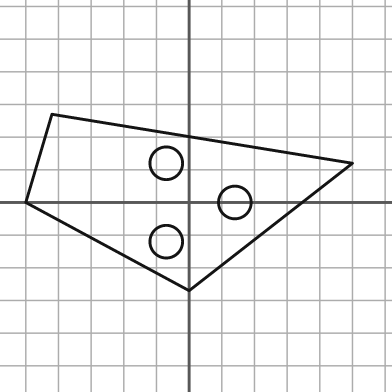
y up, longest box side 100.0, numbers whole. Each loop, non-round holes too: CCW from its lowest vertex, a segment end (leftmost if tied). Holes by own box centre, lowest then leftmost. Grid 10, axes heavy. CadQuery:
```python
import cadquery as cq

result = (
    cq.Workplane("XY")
    .moveTo(0.0, -27.0)
    .lineTo(50.0, 12.0)
    .lineTo(-42.0, 27.0)
    .lineTo(-50.0, 0.0)
    .close()
    .moveTo(-7.0, -12.0)
    .circle(5.0)
    .moveTo(14.0, 0.0)
    .circle(5.0)
    .moveTo(-7.0, 12.0)
    .circle(5.0)
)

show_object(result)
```